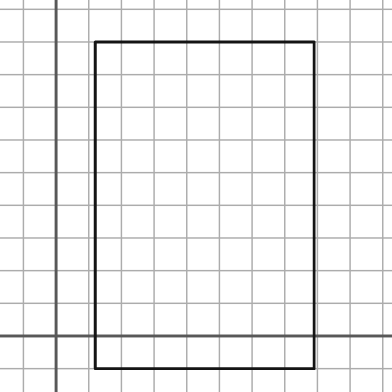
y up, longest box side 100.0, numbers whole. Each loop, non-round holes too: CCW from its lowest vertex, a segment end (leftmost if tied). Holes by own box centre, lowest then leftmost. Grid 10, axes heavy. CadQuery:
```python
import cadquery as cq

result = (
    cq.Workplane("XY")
    .moveTo(12.0, -10.0)
    .lineTo(79.0, -10.0)
    .lineTo(79.0, 90.0)
    .lineTo(12.0, 90.0)
    .close()
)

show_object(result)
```